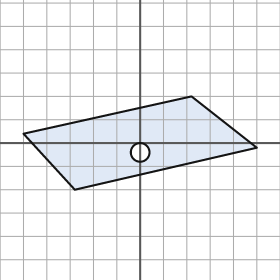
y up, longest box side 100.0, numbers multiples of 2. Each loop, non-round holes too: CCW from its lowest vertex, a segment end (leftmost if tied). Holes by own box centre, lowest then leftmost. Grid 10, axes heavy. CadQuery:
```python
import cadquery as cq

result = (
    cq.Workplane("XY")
    .moveTo(-28.0, -20.0)
    .lineTo(50.0, -2.0)
    .lineTo(22.0, 20.0)
    .lineTo(-50.0, 4.0)
    .close()
    .moveTo(0.0, -4.0)
    .circle(4.0)
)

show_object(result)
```